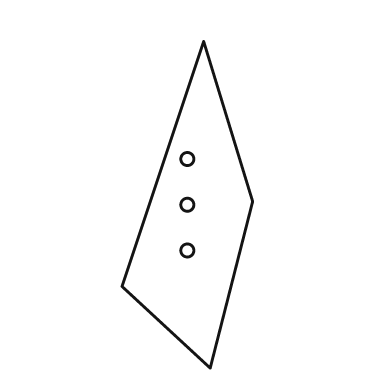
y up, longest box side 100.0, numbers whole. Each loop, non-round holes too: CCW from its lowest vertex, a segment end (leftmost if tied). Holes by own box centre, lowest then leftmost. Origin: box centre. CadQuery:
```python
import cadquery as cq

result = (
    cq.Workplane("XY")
    .moveTo(7.0, -50.0)
    .lineTo(20.0, 1.0)
    .lineTo(5.0, 50.0)
    .lineTo(-20.0, -25.0)
    .close()
    .moveTo(0.0, -14.0)
    .circle(2.0)
    .moveTo(0.0, 0.0)
    .circle(2.0)
    .moveTo(0.0, 14.0)
    .circle(2.0)
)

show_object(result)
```